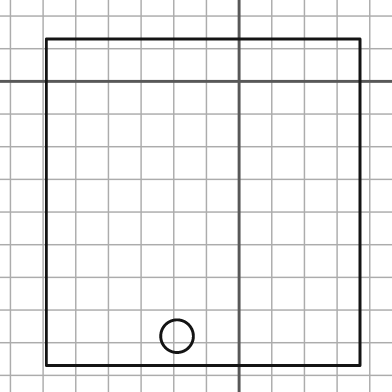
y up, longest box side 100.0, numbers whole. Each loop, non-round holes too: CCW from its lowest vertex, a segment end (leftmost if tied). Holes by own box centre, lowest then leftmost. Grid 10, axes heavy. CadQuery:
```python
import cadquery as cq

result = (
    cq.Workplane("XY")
    .moveTo(-59.0, -87.0)
    .lineTo(37.0, -87.0)
    .lineTo(37.0, 13.0)
    .lineTo(-59.0, 13.0)
    .close()
    .moveTo(-19.0, -78.0)
    .circle(5.0)
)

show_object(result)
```